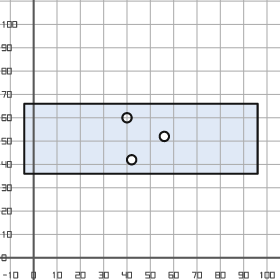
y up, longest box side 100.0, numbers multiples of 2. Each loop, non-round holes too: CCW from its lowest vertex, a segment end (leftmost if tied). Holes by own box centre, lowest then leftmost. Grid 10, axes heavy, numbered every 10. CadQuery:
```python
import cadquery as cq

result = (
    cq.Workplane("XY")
    .moveTo(-4.0, 36.0)
    .lineTo(96.0, 36.0)
    .lineTo(96.0, 66.0)
    .lineTo(-4.0, 66.0)
    .close()
    .moveTo(42.0, 42.0)
    .circle(2.0)
    .moveTo(56.0, 52.0)
    .circle(2.0)
    .moveTo(40.0, 60.0)
    .circle(2.0)
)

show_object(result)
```